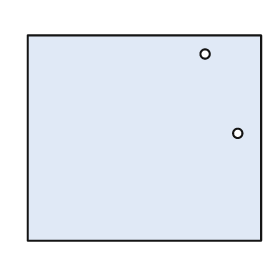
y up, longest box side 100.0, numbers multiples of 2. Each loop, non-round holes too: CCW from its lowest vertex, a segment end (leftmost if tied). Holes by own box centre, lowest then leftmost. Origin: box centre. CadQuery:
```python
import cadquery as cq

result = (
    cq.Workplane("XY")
    .moveTo(-50.0, -44.0)
    .lineTo(50.0, -44.0)
    .lineTo(50.0, 44.0)
    .lineTo(-50.0, 44.0)
    .close()
    .moveTo(40.0, 2.0)
    .circle(2.0)
    .moveTo(26.0, 36.0)
    .circle(2.0)
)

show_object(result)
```